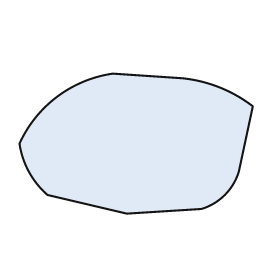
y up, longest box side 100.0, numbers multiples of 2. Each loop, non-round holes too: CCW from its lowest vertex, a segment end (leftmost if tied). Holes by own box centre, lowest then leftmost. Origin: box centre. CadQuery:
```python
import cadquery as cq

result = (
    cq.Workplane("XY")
    .moveTo(-4.0, -30.0)
    .lineTo(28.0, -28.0)
    .threePointArc((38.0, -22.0), (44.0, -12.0))
    .lineTo(50.0, 16.0)
    .threePointArc((36.0, 24.0), (20.0, 28.0))
    .lineTo(-10.0, 30.0)
    .threePointArc((-34.0, 20.0), (-50.0, 0.0))
    .threePointArc((-46.0, -12.0), (-38.0, -22.0))
    .close()
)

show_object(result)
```